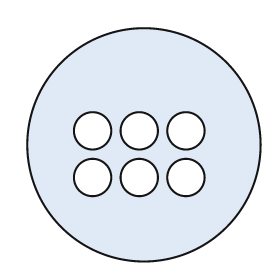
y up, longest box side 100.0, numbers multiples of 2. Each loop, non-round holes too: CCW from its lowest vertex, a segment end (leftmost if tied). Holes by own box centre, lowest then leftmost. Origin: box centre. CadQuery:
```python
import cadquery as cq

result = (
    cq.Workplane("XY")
    .moveTo(0.0, 0.0)
    .circle(50.0)
    .moveTo(-22.0, -14.0)
    .circle(8.0)
    .moveTo(-2.0, -14.0)
    .circle(8.0)
    .moveTo(18.0, -14.0)
    .circle(8.0)
    .moveTo(-22.0, 6.0)
    .circle(8.0)
    .moveTo(-2.0, 6.0)
    .circle(8.0)
    .moveTo(18.0, 6.0)
    .circle(8.0)
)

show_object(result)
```